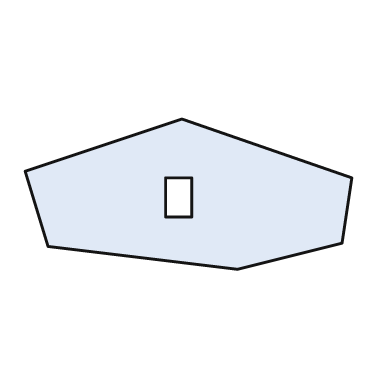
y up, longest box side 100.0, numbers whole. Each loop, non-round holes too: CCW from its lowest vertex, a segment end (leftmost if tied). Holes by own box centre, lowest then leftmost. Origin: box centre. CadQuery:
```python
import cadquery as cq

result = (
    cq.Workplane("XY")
    .moveTo(15.0, -23.0)
    .lineTo(47.0, -15.0)
    .lineTo(50.0, 5.0)
    .lineTo(-2.0, 23.0)
    .lineTo(-50.0, 7.0)
    .lineTo(-43.0, -16.0)
    .close()
    .moveTo(-7.0, -7.0)
    .lineTo(1.0, -7.0)
    .lineTo(1.0, 5.0)
    .lineTo(-7.0, 5.0)
    .close()
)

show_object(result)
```